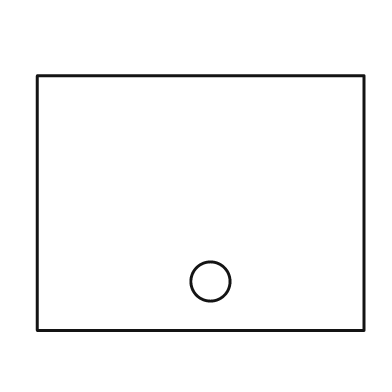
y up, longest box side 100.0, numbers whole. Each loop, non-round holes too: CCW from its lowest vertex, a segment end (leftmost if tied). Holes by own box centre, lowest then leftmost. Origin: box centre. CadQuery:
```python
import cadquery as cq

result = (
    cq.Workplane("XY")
    .moveTo(-50.0, -39.0)
    .lineTo(50.0, -39.0)
    .lineTo(50.0, 39.0)
    .lineTo(-50.0, 39.0)
    .close()
    .moveTo(3.0, -24.0)
    .circle(6.0)
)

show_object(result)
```